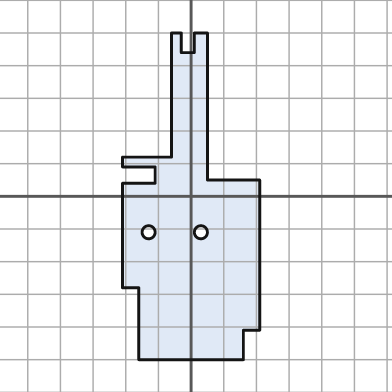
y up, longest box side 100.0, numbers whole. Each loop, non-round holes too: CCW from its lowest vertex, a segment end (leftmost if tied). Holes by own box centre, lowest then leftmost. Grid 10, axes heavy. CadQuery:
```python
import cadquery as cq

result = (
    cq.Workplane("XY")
    .moveTo(-16.0, -50.0)
    .lineTo(16.0, -50.0)
    .lineTo(16.0, -41.0)
    .lineTo(21.0, -41.0)
    .lineTo(21.0, 5.0)
    .lineTo(5.0, 5.0)
    .lineTo(5.0, 50.0)
    .lineTo(1.0, 50.0)
    .lineTo(1.0, 44.0)
    .lineTo(-3.0, 44.0)
    .lineTo(-3.0, 50.0)
    .lineTo(-6.0, 50.0)
    .lineTo(-6.0, 12.0)
    .lineTo(-21.0, 12.0)
    .lineTo(-21.0, 9.0)
    .lineTo(-11.0, 9.0)
    .lineTo(-11.0, 4.0)
    .lineTo(-21.0, 4.0)
    .lineTo(-21.0, -28.0)
    .lineTo(-16.0, -28.0)
    .close()
    .moveTo(-13.0, -11.0)
    .circle(2.0)
    .moveTo(3.0, -11.0)
    .circle(2.0)
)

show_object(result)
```